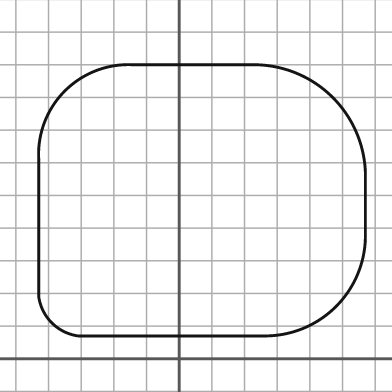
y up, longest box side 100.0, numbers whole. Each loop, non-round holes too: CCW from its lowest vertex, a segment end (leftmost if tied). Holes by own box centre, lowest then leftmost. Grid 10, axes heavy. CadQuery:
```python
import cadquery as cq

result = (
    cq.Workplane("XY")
    .moveTo(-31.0, 7.0)
    .lineTo(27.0, 7.0)
    .threePointArc((48.0, 16.0), (57.0, 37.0))
    .lineTo(57.0, 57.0)
    .threePointArc((47.0, 80.0), (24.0, 90.0))
    .lineTo(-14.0, 90.0)
    .threePointArc((-35.0, 82.0), (-43.0, 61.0))
    .lineTo(-43.0, 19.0)
    .threePointArc((-39.0, 11.0), (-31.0, 7.0))
    .close()
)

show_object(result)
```